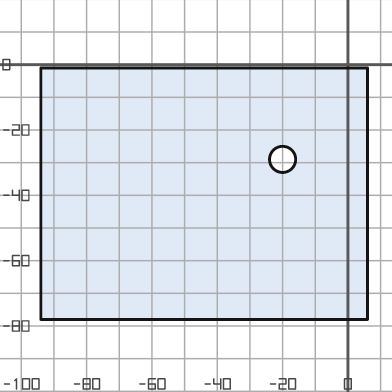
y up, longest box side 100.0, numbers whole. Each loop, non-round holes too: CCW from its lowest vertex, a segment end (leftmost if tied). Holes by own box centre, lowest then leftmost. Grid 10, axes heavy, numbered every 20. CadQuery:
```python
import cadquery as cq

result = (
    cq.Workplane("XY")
    .moveTo(-94.0, -78.0)
    .lineTo(6.0, -78.0)
    .lineTo(6.0, -1.0)
    .lineTo(-94.0, -1.0)
    .close()
    .moveTo(-20.0, -29.0)
    .circle(4.0)
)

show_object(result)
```